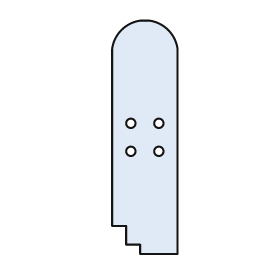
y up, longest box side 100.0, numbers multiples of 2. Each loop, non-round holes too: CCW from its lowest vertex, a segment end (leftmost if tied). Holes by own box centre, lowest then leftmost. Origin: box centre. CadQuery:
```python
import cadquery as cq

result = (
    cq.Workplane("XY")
    .moveTo(-2.0, -50.0)
    .lineTo(14.0, -50.0)
    .lineTo(14.0, 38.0)
    .threePointArc((10.0, 46.0), (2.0, 50.0))
    .lineTo(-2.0, 50.0)
    .threePointArc((-10.0, 46.0), (-14.0, 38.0))
    .lineTo(-14.0, -38.0)
    .lineTo(-8.0, -38.0)
    .lineTo(-8.0, -46.0)
    .lineTo(-2.0, -46.0)
    .close()
    .moveTo(-6.0, -6.0)
    .circle(2.0)
    .moveTo(6.0, -6.0)
    .circle(2.0)
    .moveTo(-6.0, 6.0)
    .circle(2.0)
    .moveTo(6.0, 6.0)
    .circle(2.0)
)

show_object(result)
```